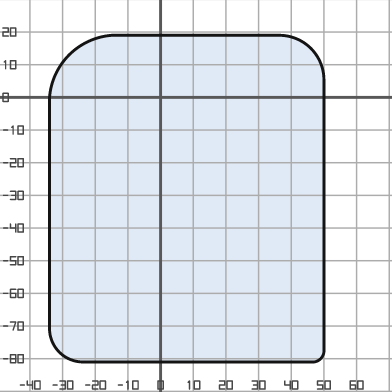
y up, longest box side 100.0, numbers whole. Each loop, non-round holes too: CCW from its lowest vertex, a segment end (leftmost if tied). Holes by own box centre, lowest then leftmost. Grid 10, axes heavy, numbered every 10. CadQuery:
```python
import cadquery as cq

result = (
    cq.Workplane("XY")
    .moveTo(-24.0, -81.0)
    .lineTo(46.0, -81.0)
    .threePointArc((49.0, -80.0), (50.0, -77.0))
    .lineTo(50.0, 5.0)
    .threePointArc((46.0, 15.0), (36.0, 19.0))
    .lineTo(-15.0, 19.0)
    .threePointArc((-28.0, 13.0), (-34.0, 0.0))
    .lineTo(-34.0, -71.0)
    .threePointArc((-31.0, -78.0), (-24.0, -81.0))
    .close()
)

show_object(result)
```